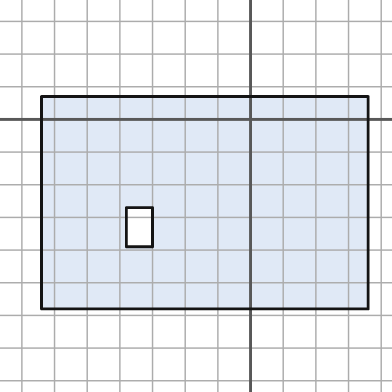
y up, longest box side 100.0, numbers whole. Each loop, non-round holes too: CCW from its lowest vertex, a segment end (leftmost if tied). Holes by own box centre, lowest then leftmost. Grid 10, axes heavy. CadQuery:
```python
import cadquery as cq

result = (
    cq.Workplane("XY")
    .moveTo(-64.0, -58.0)
    .lineTo(36.0, -58.0)
    .lineTo(36.0, 7.0)
    .lineTo(-64.0, 7.0)
    .close()
    .moveTo(-38.0, -39.0)
    .lineTo(-30.0, -39.0)
    .lineTo(-30.0, -27.0)
    .lineTo(-38.0, -27.0)
    .close()
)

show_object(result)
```